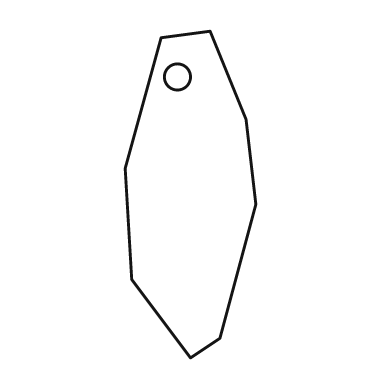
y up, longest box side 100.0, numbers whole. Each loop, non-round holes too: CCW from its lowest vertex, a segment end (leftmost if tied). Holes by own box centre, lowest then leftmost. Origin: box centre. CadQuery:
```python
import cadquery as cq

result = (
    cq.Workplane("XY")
    .moveTo(0.0, -50.0)
    .lineTo(9.0, -44.0)
    .lineTo(20.0, -3.0)
    .lineTo(17.0, 23.0)
    .lineTo(6.0, 50.0)
    .lineTo(-9.0, 48.0)
    .lineTo(-20.0, 8.0)
    .lineTo(-18.0, -26.0)
    .close()
    .moveTo(-4.0, 36.0)
    .circle(4.0)
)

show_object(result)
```